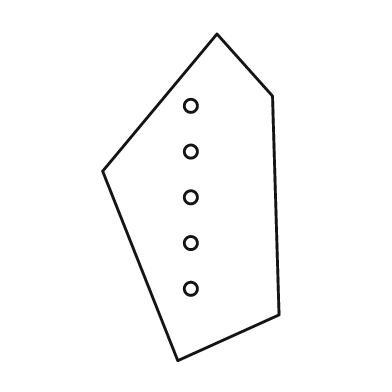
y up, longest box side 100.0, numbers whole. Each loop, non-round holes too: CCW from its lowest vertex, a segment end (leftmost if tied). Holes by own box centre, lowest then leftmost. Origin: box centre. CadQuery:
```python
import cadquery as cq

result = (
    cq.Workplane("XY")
    .moveTo(-4.0, -50.0)
    .lineTo(27.0, -36.0)
    .lineTo(25.0, 31.0)
    .lineTo(8.0, 50.0)
    .lineTo(-27.0, 8.0)
    .close()
    .moveTo(0.0, -28.0)
    .circle(2.0)
    .moveTo(0.0, -14.0)
    .circle(2.0)
    .moveTo(0.0, 0.0)
    .circle(2.0)
    .moveTo(0.0, 14.0)
    .circle(2.0)
    .moveTo(0.0, 28.0)
    .circle(2.0)
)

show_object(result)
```